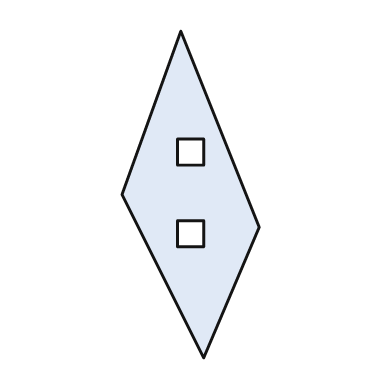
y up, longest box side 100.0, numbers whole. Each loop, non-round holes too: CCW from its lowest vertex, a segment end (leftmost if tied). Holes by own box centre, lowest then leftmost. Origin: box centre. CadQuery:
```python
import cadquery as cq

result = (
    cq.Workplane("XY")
    .moveTo(4.0, -50.0)
    .lineTo(21.0, -10.0)
    .lineTo(-3.0, 50.0)
    .lineTo(-21.0, 0.0)
    .close()
    .moveTo(-4.0, -16.0)
    .lineTo(4.0, -16.0)
    .lineTo(4.0, -8.0)
    .lineTo(-4.0, -8.0)
    .close()
    .moveTo(-4.0, 9.0)
    .lineTo(4.0, 9.0)
    .lineTo(4.0, 17.0)
    .lineTo(-4.0, 17.0)
    .close()
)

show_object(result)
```